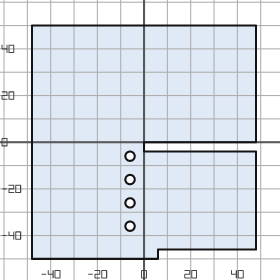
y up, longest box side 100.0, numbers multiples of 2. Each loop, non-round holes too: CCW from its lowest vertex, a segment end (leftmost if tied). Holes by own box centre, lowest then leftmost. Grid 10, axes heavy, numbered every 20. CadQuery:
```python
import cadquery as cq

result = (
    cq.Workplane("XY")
    .moveTo(-48.0, -50.0)
    .lineTo(6.0, -50.0)
    .lineTo(6.0, -46.0)
    .lineTo(48.0, -46.0)
    .lineTo(48.0, -4.0)
    .lineTo(0.0, -4.0)
    .lineTo(0.0, 0.0)
    .lineTo(48.0, 0.0)
    .lineTo(48.0, 50.0)
    .lineTo(-48.0, 50.0)
    .close()
    .moveTo(-6.0, -36.0)
    .circle(2.0)
    .moveTo(-6.0, -26.0)
    .circle(2.0)
    .moveTo(-6.0, -16.0)
    .circle(2.0)
    .moveTo(-6.0, -6.0)
    .circle(2.0)
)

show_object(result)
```